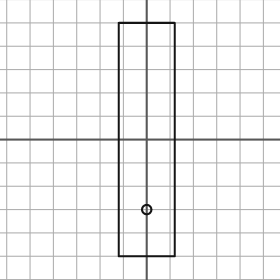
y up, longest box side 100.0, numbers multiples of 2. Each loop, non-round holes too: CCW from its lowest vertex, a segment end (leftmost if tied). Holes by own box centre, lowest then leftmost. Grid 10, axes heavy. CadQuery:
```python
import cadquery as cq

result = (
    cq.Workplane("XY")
    .moveTo(-12.0, -50.0)
    .lineTo(12.0, -50.0)
    .lineTo(12.0, 50.0)
    .lineTo(-12.0, 50.0)
    .close()
    .moveTo(0.0, -30.0)
    .circle(2.0)
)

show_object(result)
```